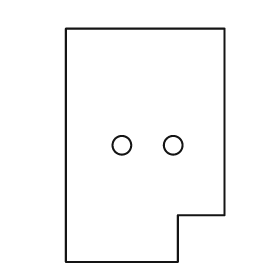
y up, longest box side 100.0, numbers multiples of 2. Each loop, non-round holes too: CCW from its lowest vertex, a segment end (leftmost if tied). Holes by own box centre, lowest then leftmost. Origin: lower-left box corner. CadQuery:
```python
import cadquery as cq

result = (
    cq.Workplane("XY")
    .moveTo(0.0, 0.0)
    .lineTo(48.0, 0.0)
    .lineTo(48.0, 20.0)
    .lineTo(68.0, 20.0)
    .lineTo(68.0, 100.0)
    .lineTo(0.0, 100.0)
    .close()
    .moveTo(24.0, 50.0)
    .circle(4.0)
    .moveTo(46.0, 50.0)
    .circle(4.0)
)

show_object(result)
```